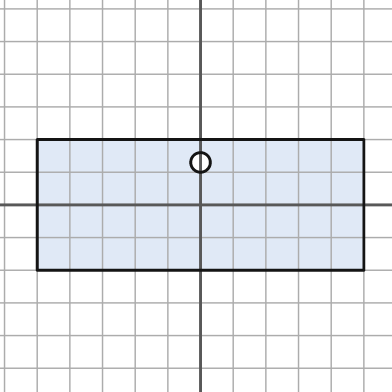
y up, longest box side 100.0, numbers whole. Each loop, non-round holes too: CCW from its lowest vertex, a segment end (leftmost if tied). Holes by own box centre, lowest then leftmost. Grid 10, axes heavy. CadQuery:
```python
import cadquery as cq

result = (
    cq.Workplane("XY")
    .moveTo(-50.0, -20.0)
    .lineTo(50.0, -20.0)
    .lineTo(50.0, 20.0)
    .lineTo(-50.0, 20.0)
    .close()
    .moveTo(0.0, 13.0)
    .circle(3.0)
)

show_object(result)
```